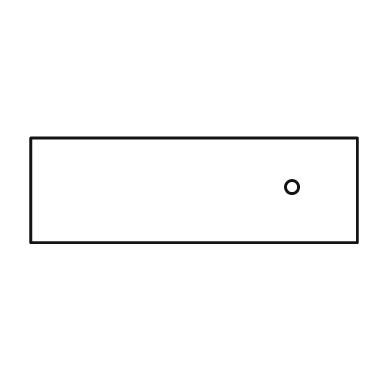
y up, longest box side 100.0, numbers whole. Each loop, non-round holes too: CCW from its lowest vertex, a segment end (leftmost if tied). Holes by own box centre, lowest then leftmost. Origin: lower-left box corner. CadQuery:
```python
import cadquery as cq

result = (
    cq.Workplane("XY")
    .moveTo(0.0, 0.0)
    .lineTo(100.0, 0.0)
    .lineTo(100.0, 32.0)
    .lineTo(0.0, 32.0)
    .close()
    .moveTo(80.0, 17.0)
    .circle(2.0)
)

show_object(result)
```